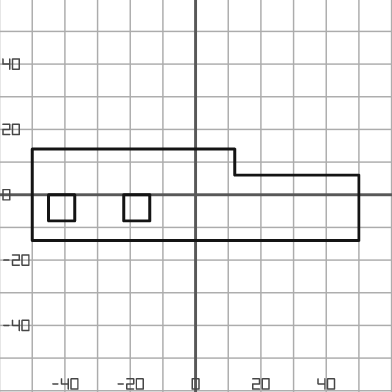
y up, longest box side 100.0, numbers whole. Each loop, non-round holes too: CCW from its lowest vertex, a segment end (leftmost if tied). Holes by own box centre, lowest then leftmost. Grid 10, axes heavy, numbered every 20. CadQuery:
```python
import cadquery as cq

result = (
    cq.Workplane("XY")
    .moveTo(-50.0, -14.0)
    .lineTo(50.0, -14.0)
    .lineTo(50.0, 6.0)
    .lineTo(12.0, 6.0)
    .lineTo(12.0, 14.0)
    .lineTo(-50.0, 14.0)
    .close()
    .moveTo(-45.0, -8.0)
    .lineTo(-37.0, -8.0)
    .lineTo(-37.0, 0.0)
    .lineTo(-45.0, 0.0)
    .close()
    .moveTo(-22.0, -8.0)
    .lineTo(-14.0, -8.0)
    .lineTo(-14.0, 0.0)
    .lineTo(-22.0, 0.0)
    .close()
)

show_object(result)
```